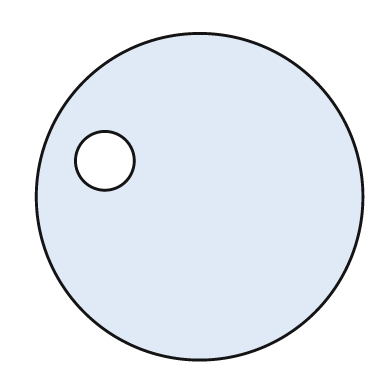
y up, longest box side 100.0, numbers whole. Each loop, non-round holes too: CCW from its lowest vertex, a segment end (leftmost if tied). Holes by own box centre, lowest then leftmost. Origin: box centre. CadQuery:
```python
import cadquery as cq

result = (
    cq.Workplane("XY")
    .moveTo(0.0, 0.0)
    .circle(50.0)
    .moveTo(-29.0, 11.0)
    .circle(9.0)
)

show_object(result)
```